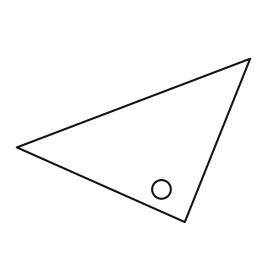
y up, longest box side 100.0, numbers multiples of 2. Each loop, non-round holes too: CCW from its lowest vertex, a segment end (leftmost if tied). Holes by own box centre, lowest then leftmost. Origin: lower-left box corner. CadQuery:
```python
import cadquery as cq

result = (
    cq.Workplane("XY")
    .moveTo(72.0, 0.0)
    .lineTo(100.0, 70.0)
    .lineTo(0.0, 32.0)
    .close()
    .moveTo(62.0, 14.0)
    .circle(4.0)
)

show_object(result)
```